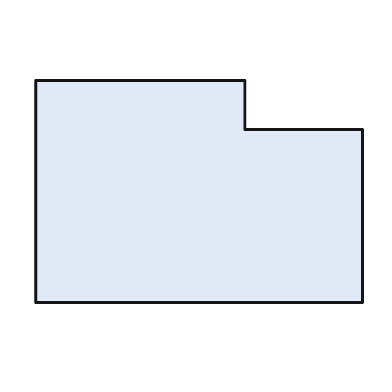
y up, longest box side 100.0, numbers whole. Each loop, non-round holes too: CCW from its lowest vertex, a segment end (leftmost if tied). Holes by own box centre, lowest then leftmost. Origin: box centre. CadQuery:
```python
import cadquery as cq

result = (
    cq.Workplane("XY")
    .moveTo(-50.0, -34.0)
    .lineTo(50.0, -34.0)
    .lineTo(50.0, 19.0)
    .lineTo(14.0, 19.0)
    .lineTo(14.0, 34.0)
    .lineTo(-50.0, 34.0)
    .close()
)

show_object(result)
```